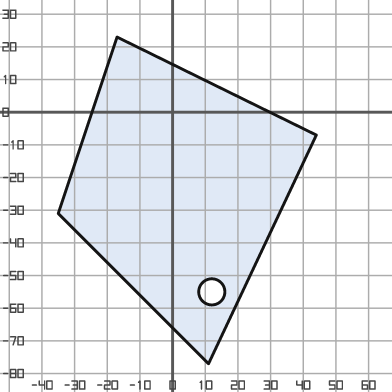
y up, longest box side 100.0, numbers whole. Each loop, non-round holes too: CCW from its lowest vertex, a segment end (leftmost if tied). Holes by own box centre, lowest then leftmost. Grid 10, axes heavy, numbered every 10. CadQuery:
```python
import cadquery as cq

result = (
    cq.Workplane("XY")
    .moveTo(11.0, -77.0)
    .lineTo(44.0, -7.0)
    .lineTo(-17.0, 23.0)
    .lineTo(-35.0, -31.0)
    .close()
    .moveTo(12.0, -55.0)
    .circle(4.0)
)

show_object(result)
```